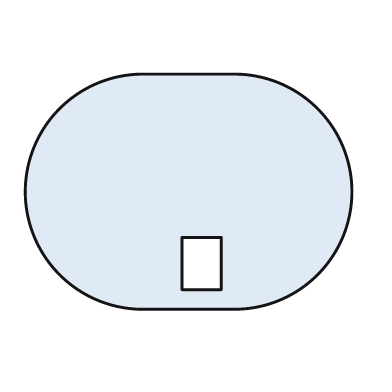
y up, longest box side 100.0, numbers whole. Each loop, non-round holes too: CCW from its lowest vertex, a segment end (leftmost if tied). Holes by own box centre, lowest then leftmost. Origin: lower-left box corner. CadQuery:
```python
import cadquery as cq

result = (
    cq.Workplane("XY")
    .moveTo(36.0, 0.0)
    .lineTo(64.0, 0.0)
    .threePointArc((100.0, 36.0), (64.0, 72.0))
    .lineTo(36.0, 72.0)
    .threePointArc((0.0, 36.0), (36.0, 0.0))
    .close()
    .moveTo(48.0, 6.0)
    .lineTo(60.0, 6.0)
    .lineTo(60.0, 22.0)
    .lineTo(48.0, 22.0)
    .close()
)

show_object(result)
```